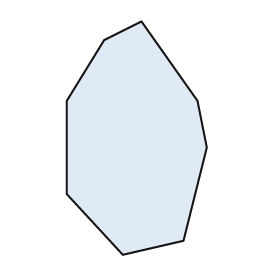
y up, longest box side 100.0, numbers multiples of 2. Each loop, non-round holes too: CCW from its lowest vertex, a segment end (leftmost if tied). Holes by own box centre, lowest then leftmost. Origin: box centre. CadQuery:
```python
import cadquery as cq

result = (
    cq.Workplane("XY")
    .moveTo(-6.0, -50.0)
    .lineTo(20.0, -44.0)
    .lineTo(30.0, -4.0)
    .lineTo(26.0, 16.0)
    .lineTo(2.0, 50.0)
    .lineTo(-14.0, 42.0)
    .lineTo(-30.0, 16.0)
    .lineTo(-30.0, -24.0)
    .close()
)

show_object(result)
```